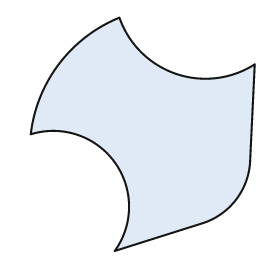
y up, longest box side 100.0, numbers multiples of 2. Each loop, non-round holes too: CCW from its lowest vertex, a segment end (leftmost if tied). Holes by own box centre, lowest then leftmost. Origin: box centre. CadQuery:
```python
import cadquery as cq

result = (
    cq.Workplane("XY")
    .moveTo(-12.0, -50.0)
    .lineTo(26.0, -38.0)
    .threePointArc((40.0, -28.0), (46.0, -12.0))
    .lineTo(48.0, 30.0)
    .threePointArc((14.0, 26.0), (-10.0, 50.0))
    .threePointArc((-36.0, 30.0), (-48.0, 0.0))
    .threePointArc((-12.0, -12.0), (-12.0, -50.0))
    .close()
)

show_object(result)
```